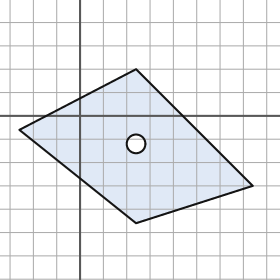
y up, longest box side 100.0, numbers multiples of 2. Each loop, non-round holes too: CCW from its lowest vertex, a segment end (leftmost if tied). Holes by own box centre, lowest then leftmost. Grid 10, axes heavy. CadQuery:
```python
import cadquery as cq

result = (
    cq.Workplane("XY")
    .moveTo(24.0, -46.0)
    .lineTo(74.0, -30.0)
    .lineTo(24.0, 20.0)
    .lineTo(-26.0, -6.0)
    .close()
    .moveTo(24.0, -12.0)
    .circle(4.0)
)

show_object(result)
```